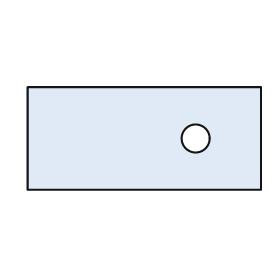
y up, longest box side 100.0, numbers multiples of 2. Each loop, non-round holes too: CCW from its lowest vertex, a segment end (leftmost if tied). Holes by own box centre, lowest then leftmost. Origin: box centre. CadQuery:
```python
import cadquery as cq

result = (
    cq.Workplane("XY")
    .moveTo(-50.0, -22.0)
    .lineTo(50.0, -22.0)
    .lineTo(50.0, 22.0)
    .lineTo(-50.0, 22.0)
    .close()
    .moveTo(22.0, 0.0)
    .circle(6.0)
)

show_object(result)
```